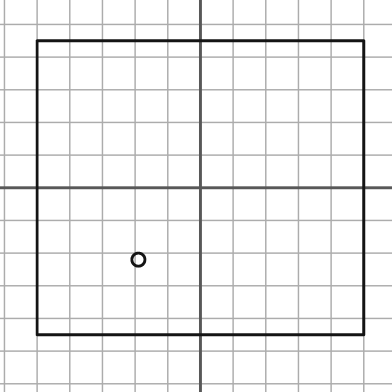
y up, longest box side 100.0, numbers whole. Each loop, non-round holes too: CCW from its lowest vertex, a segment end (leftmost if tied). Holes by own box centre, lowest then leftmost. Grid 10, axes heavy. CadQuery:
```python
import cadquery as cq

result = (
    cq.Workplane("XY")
    .moveTo(-50.0, -45.0)
    .lineTo(50.0, -45.0)
    .lineTo(50.0, 45.0)
    .lineTo(-50.0, 45.0)
    .close()
    .moveTo(-19.0, -22.0)
    .circle(2.0)
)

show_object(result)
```